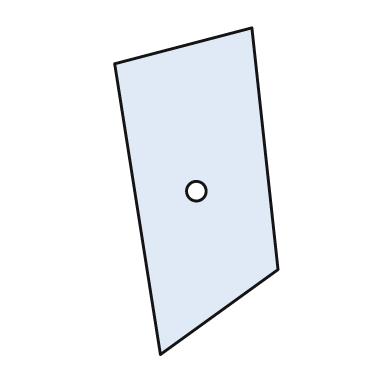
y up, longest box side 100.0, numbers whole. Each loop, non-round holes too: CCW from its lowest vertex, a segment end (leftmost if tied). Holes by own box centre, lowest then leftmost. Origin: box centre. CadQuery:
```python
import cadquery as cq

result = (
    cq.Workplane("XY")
    .moveTo(-11.0, -50.0)
    .lineTo(25.0, -24.0)
    .lineTo(17.0, 50.0)
    .lineTo(-25.0, 39.0)
    .close()
    .moveTo(0.0, 0.0)
    .circle(3.0)
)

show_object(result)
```